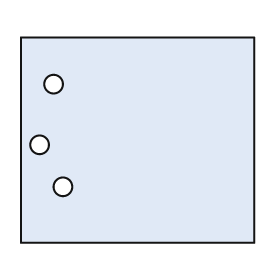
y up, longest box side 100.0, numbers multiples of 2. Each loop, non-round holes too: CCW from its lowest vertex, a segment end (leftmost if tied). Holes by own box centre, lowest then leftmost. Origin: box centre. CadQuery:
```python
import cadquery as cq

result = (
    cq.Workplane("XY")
    .moveTo(-50.0, -44.0)
    .lineTo(50.0, -44.0)
    .lineTo(50.0, 44.0)
    .lineTo(-50.0, 44.0)
    .close()
    .moveTo(-32.0, -20.0)
    .circle(4.0)
    .moveTo(-42.0, -2.0)
    .circle(4.0)
    .moveTo(-36.0, 24.0)
    .circle(4.0)
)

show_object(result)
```